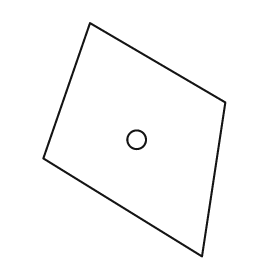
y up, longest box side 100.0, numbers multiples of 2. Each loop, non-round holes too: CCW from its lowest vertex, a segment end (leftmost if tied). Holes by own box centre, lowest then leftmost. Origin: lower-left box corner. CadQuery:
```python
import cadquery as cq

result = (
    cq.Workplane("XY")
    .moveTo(68.0, 0.0)
    .lineTo(78.0, 66.0)
    .lineTo(20.0, 100.0)
    .lineTo(0.0, 42.0)
    .close()
    .moveTo(40.0, 50.0)
    .circle(4.0)
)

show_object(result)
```